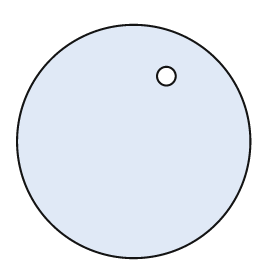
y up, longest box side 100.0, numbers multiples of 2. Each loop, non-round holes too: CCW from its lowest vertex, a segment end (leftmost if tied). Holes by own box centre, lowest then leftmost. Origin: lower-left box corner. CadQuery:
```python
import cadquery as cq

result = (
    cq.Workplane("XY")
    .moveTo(50.0, 50.0)
    .circle(50.0)
    .moveTo(64.0, 78.0)
    .circle(4.0)
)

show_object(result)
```